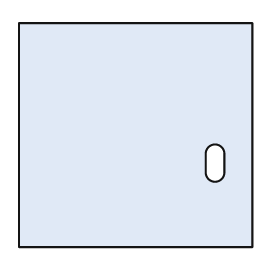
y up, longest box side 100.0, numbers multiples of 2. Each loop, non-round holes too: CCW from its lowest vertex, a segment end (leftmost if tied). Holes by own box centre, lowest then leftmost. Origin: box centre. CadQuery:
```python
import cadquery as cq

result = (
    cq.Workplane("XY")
    .moveTo(-50.0, -48.0)
    .lineTo(50.0, -48.0)
    .lineTo(50.0, 48.0)
    .lineTo(-50.0, 48.0)
    .close()
    .moveTo(30.0, -16.0)
    .threePointArc((34.0, -20.0), (38.0, -16.0))
    .lineTo(38.0, -8.0)
    .threePointArc((34.0, -4.0), (30.0, -8.0))
    .close()
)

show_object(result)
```